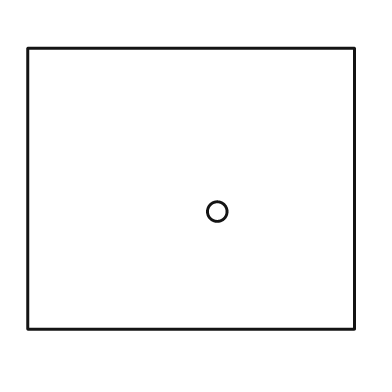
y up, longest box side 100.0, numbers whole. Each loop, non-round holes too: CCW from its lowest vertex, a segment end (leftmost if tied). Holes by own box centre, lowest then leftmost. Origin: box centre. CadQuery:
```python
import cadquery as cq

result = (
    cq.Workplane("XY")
    .moveTo(-50.0, -43.0)
    .lineTo(50.0, -43.0)
    .lineTo(50.0, 43.0)
    .lineTo(-50.0, 43.0)
    .close()
    .moveTo(8.0, -7.0)
    .circle(3.0)
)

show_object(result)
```